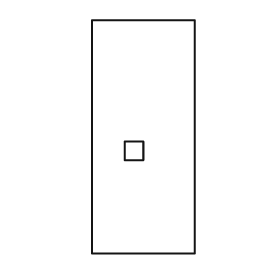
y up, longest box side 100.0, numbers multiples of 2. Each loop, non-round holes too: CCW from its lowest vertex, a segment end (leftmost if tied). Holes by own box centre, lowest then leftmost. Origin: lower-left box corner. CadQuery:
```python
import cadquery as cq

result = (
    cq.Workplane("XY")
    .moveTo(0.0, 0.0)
    .lineTo(44.0, 0.0)
    .lineTo(44.0, 100.0)
    .lineTo(0.0, 100.0)
    .close()
    .moveTo(14.0, 40.0)
    .lineTo(22.0, 40.0)
    .lineTo(22.0, 48.0)
    .lineTo(14.0, 48.0)
    .close()
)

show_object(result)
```